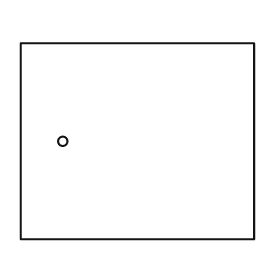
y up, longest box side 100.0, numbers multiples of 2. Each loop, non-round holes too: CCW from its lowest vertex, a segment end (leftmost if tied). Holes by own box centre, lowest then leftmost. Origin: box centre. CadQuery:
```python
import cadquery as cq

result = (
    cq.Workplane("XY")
    .moveTo(-50.0, -42.0)
    .lineTo(50.0, -42.0)
    .lineTo(50.0, 42.0)
    .lineTo(-50.0, 42.0)
    .close()
    .moveTo(-32.0, 0.0)
    .circle(2.0)
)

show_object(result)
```